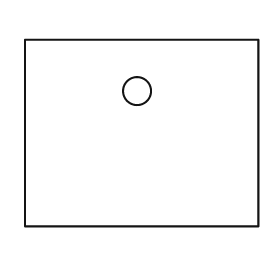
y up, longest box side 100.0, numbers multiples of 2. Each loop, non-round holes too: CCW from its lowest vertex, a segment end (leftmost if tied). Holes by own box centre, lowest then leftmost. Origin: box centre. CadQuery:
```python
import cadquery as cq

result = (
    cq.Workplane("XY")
    .moveTo(-50.0, -40.0)
    .lineTo(50.0, -40.0)
    .lineTo(50.0, 40.0)
    .lineTo(-50.0, 40.0)
    .close()
    .moveTo(-2.0, 18.0)
    .circle(6.0)
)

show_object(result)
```